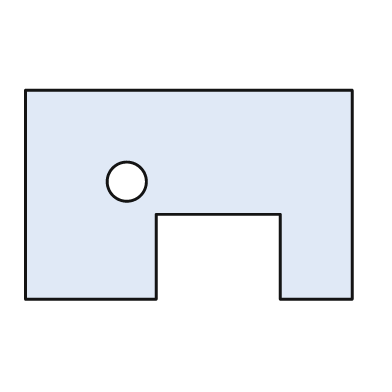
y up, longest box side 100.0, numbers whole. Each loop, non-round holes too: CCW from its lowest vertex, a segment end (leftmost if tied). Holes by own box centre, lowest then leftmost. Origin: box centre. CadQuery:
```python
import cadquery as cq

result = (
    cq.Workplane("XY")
    .moveTo(-50.0, -32.0)
    .lineTo(-10.0, -32.0)
    .lineTo(-10.0, -6.0)
    .lineTo(28.0, -6.0)
    .lineTo(28.0, -32.0)
    .lineTo(50.0, -32.0)
    .lineTo(50.0, 32.0)
    .lineTo(-50.0, 32.0)
    .close()
    .moveTo(-19.0, 4.0)
    .circle(6.0)
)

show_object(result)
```